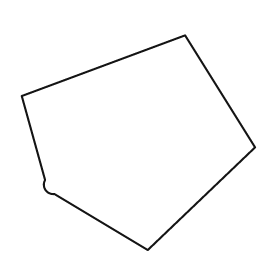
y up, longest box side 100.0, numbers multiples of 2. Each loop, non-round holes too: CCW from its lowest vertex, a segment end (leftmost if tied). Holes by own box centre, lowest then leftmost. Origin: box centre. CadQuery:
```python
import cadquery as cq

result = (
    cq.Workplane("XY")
    .moveTo(4.0, -46.0)
    .lineTo(50.0, -2.0)
    .lineTo(20.0, 46.0)
    .lineTo(-50.0, 20.0)
    .lineTo(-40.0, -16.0)
    .threePointArc((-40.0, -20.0), (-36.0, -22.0))
    .close()
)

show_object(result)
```